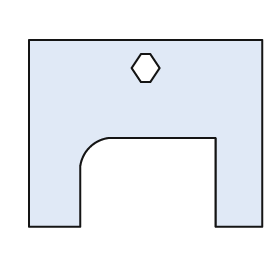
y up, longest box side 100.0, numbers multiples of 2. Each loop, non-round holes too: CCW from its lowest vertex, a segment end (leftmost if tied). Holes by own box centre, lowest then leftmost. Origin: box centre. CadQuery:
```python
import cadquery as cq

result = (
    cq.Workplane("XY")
    .moveTo(-50.0, -40.0)
    .lineTo(-28.0, -40.0)
    .lineTo(-28.0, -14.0)
    .threePointArc((-24.0, -6.0), (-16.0, -2.0))
    .lineTo(30.0, -2.0)
    .lineTo(30.0, -40.0)
    .lineTo(50.0, -40.0)
    .lineTo(50.0, 40.0)
    .lineTo(-50.0, 40.0)
    .close()
    .moveTo(-2.0, 22.0)
    .lineTo(2.0, 22.0)
    .lineTo(6.0, 28.0)
    .lineTo(2.0, 34.0)
    .lineTo(-2.0, 34.0)
    .lineTo(-6.0, 28.0)
    .close()
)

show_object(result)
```